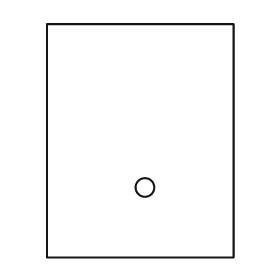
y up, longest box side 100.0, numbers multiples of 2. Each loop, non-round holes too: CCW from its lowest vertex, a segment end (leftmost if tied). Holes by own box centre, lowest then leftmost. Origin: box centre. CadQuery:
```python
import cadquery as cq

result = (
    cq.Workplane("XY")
    .moveTo(-40.0, -50.0)
    .lineTo(40.0, -50.0)
    .lineTo(40.0, 50.0)
    .lineTo(-40.0, 50.0)
    .close()
    .moveTo(2.0, -20.0)
    .circle(4.0)
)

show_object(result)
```